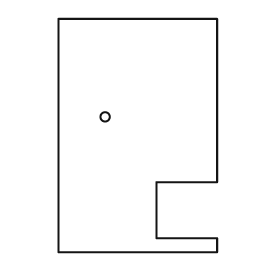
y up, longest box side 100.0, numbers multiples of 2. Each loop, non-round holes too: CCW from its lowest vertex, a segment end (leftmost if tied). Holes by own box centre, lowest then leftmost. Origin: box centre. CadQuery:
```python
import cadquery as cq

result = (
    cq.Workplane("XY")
    .moveTo(-34.0, -50.0)
    .lineTo(34.0, -50.0)
    .lineTo(34.0, -44.0)
    .lineTo(8.0, -44.0)
    .lineTo(8.0, -20.0)
    .lineTo(34.0, -20.0)
    .lineTo(34.0, 50.0)
    .lineTo(-34.0, 50.0)
    .close()
    .moveTo(-14.0, 8.0)
    .circle(2.0)
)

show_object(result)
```